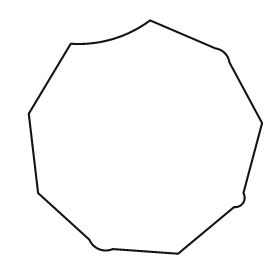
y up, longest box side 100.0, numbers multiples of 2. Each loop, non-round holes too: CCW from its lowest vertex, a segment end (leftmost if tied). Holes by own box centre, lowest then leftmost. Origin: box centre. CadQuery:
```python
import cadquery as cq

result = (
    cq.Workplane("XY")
    .moveTo(14.0, -50.0)
    .lineTo(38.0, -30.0)
    .threePointArc((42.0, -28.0), (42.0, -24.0))
    .lineTo(50.0, 6.0)
    .lineTo(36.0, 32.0)
    .threePointArc((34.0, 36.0), (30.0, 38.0))
    .lineTo(2.0, 50.0)
    .threePointArc((-14.0, 42.0), (-32.0, 40.0))
    .lineTo(-50.0, 10.0)
    .lineTo(-46.0, -24.0)
    .lineTo(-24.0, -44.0)
    .threePointArc((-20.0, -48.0), (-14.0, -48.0))
    .close()
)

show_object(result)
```